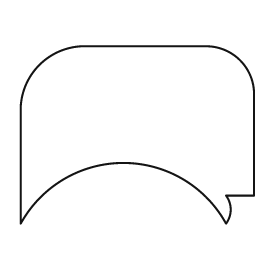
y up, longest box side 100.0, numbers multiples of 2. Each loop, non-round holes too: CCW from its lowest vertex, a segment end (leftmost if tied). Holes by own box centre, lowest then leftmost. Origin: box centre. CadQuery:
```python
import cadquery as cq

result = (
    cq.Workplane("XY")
    .moveTo(-50.0, -38.0)
    .threePointArc((-6.0, -12.0), (38.0, -38.0))
    .threePointArc((40.0, -32.0), (38.0, -26.0))
    .lineTo(50.0, -26.0)
    .lineTo(50.0, 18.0)
    .threePointArc((44.0, 32.0), (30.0, 38.0))
    .lineTo(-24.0, 38.0)
    .threePointArc((-42.0, 30.0), (-50.0, 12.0))
    .close()
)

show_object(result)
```